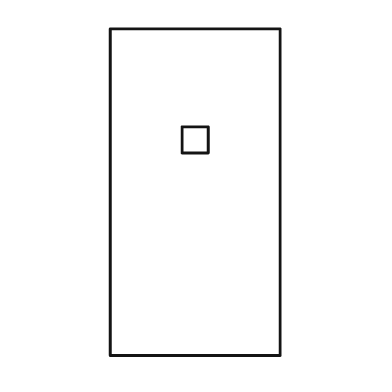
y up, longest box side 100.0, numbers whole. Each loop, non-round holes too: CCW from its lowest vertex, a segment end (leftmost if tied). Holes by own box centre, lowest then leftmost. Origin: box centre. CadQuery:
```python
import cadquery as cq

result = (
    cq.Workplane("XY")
    .moveTo(-26.0, -50.0)
    .lineTo(26.0, -50.0)
    .lineTo(26.0, 50.0)
    .lineTo(-26.0, 50.0)
    .close()
    .moveTo(-4.0, 12.0)
    .lineTo(4.0, 12.0)
    .lineTo(4.0, 20.0)
    .lineTo(-4.0, 20.0)
    .close()
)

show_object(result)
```